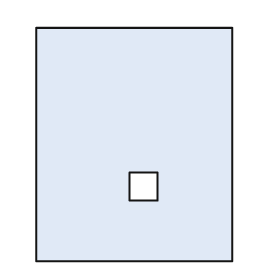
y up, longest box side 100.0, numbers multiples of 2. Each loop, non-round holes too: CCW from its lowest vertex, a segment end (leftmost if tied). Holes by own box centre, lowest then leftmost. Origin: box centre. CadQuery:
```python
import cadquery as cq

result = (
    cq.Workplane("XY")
    .moveTo(-42.0, -50.0)
    .lineTo(42.0, -50.0)
    .lineTo(42.0, 50.0)
    .lineTo(-42.0, 50.0)
    .close()
    .moveTo(-2.0, -24.0)
    .lineTo(10.0, -24.0)
    .lineTo(10.0, -12.0)
    .lineTo(-2.0, -12.0)
    .close()
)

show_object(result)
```